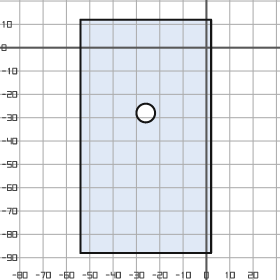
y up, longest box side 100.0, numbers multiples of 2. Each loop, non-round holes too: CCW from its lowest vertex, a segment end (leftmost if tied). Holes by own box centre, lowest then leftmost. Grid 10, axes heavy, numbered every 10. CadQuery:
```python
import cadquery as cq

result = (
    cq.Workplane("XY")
    .moveTo(-54.0, -88.0)
    .lineTo(2.0, -88.0)
    .lineTo(2.0, 12.0)
    .lineTo(-54.0, 12.0)
    .close()
    .moveTo(-26.0, -28.0)
    .circle(4.0)
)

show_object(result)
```